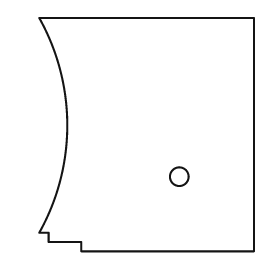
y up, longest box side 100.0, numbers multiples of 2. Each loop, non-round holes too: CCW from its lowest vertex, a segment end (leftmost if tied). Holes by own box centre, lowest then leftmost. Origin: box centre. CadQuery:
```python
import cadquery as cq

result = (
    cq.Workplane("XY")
    .moveTo(-28.0, -50.0)
    .lineTo(46.0, -50.0)
    .lineTo(46.0, 50.0)
    .lineTo(-46.0, 50.0)
    .threePointArc((-34.0, 4.0), (-46.0, -42.0))
    .lineTo(-42.0, -42.0)
    .lineTo(-42.0, -46.0)
    .lineTo(-28.0, -46.0)
    .close()
    .moveTo(14.0, -18.0)
    .circle(4.0)
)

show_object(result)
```